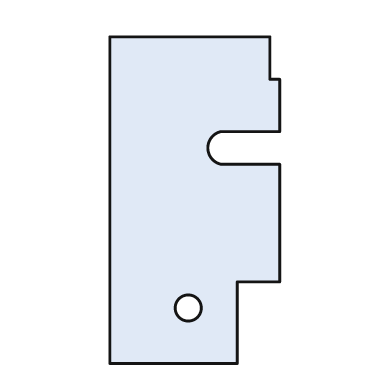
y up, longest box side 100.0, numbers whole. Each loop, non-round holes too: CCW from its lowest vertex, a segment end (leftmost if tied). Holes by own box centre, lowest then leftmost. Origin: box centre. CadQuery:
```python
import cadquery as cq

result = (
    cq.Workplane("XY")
    .moveTo(-26.0, -50.0)
    .lineTo(13.0, -50.0)
    .lineTo(13.0, -25.0)
    .lineTo(26.0, -25.0)
    .lineTo(26.0, 11.0)
    .lineTo(8.0, 11.0)
    .threePointArc((4.0, 16.0), (8.0, 21.0))
    .lineTo(26.0, 21.0)
    .lineTo(26.0, 37.0)
    .lineTo(23.0, 37.0)
    .lineTo(23.0, 50.0)
    .lineTo(-26.0, 50.0)
    .close()
    .moveTo(-2.0, -33.0)
    .circle(4.0)
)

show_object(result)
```